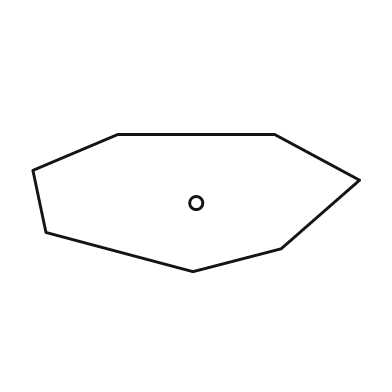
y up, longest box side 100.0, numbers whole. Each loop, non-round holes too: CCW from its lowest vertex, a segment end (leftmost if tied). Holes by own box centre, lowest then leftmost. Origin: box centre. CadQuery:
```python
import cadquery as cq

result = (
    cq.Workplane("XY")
    .moveTo(-1.0, -21.0)
    .lineTo(26.0, -14.0)
    .lineTo(50.0, 7.0)
    .lineTo(24.0, 21.0)
    .lineTo(-24.0, 21.0)
    .lineTo(-50.0, 10.0)
    .lineTo(-46.0, -9.0)
    .close()
    .moveTo(0.0, 0.0)
    .circle(2.0)
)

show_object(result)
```